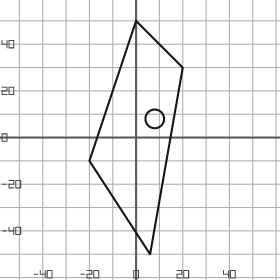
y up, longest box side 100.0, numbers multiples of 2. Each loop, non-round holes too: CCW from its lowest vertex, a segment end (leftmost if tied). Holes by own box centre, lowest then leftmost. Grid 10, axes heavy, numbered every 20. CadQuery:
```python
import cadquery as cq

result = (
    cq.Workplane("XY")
    .moveTo(6.0, -50.0)
    .lineTo(20.0, 30.0)
    .lineTo(0.0, 50.0)
    .lineTo(-20.0, -10.0)
    .close()
    .moveTo(8.0, 8.0)
    .circle(4.0)
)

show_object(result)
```